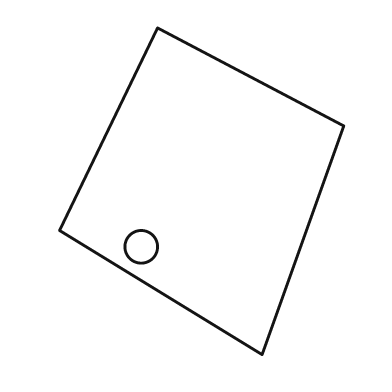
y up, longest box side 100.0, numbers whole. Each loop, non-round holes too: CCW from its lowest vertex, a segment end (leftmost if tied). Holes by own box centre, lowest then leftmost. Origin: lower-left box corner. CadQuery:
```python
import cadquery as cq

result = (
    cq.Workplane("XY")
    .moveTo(62.0, 0.0)
    .lineTo(87.0, 70.0)
    .lineTo(30.0, 100.0)
    .lineTo(0.0, 38.0)
    .close()
    .moveTo(25.0, 33.0)
    .circle(5.0)
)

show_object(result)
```